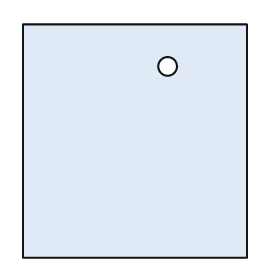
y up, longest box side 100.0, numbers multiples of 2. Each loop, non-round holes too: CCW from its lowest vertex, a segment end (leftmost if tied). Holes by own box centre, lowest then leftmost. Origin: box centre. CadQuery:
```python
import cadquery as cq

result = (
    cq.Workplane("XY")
    .moveTo(-48.0, -50.0)
    .lineTo(48.0, -50.0)
    .lineTo(48.0, 50.0)
    .lineTo(-48.0, 50.0)
    .close()
    .moveTo(14.0, 32.0)
    .circle(4.0)
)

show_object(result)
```